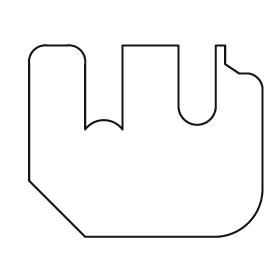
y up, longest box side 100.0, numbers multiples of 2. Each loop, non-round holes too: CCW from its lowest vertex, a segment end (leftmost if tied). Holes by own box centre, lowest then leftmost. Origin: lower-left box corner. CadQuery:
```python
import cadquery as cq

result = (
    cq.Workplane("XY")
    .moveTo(24.0, 0.0)
    .lineTo(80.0, 0.0)
    .threePointArc((94.0, 6.0), (100.0, 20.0))
    .lineTo(100.0, 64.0)
    .threePointArc((98.0, 68.0), (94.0, 70.0))
    .lineTo(90.0, 70.0)
    .lineTo(84.0, 74.0)
    .lineTo(84.0, 82.0)
    .lineTo(80.0, 82.0)
    .lineTo(80.0, 56.0)
    .threePointArc((72.0, 48.0), (64.0, 56.0))
    .lineTo(64.0, 82.0)
    .lineTo(40.0, 82.0)
    .lineTo(40.0, 46.0)
    .threePointArc((32.0, 50.0), (24.0, 46.0))
    .lineTo(24.0, 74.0)
    .threePointArc((22.0, 80.0), (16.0, 82.0))
    .lineTo(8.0, 82.0)
    .threePointArc((2.0, 80.0), (0.0, 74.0))
    .lineTo(0.0, 24.0)
    .close()
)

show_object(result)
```